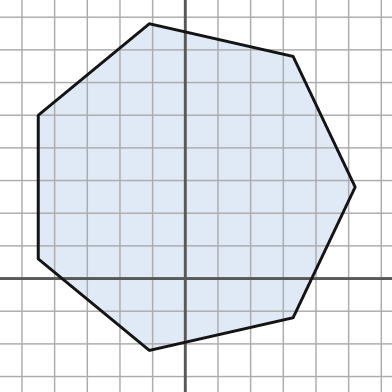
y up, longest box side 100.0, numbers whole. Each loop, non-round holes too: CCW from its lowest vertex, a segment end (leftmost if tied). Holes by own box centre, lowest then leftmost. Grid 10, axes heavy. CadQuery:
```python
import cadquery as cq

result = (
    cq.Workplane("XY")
    .moveTo(-11.0, -22.0)
    .lineTo(33.0, -12.0)
    .lineTo(52.0, 28.0)
    .lineTo(33.0, 68.0)
    .lineTo(-11.0, 78.0)
    .lineTo(-45.0, 50.0)
    .lineTo(-45.0, 6.0)
    .close()
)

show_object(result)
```